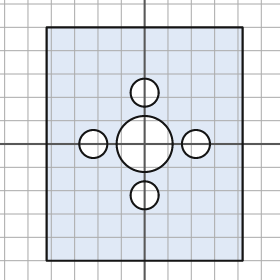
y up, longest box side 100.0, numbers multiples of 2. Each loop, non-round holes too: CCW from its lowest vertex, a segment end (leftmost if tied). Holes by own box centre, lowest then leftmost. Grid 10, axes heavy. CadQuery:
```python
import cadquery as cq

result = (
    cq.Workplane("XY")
    .moveTo(-42.0, -50.0)
    .lineTo(42.0, -50.0)
    .lineTo(42.0, 50.0)
    .lineTo(-42.0, 50.0)
    .close()
    .moveTo(0.0, -22.0)
    .circle(6.0)
    .moveTo(-22.0, 0.0)
    .circle(6.0)
    .moveTo(0.0, 0.0)
    .circle(12.0)
    .moveTo(22.0, 0.0)
    .circle(6.0)
    .moveTo(0.0, 22.0)
    .circle(6.0)
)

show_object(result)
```